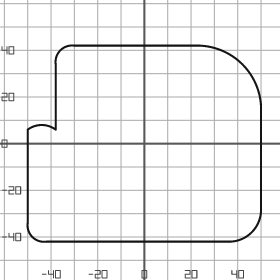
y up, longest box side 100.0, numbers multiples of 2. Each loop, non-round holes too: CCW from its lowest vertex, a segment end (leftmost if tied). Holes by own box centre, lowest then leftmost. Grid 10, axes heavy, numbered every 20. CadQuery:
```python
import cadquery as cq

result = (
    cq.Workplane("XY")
    .moveTo(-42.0, -42.0)
    .lineTo(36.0, -42.0)
    .threePointArc((46.0, -38.0), (50.0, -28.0))
    .lineTo(50.0, 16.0)
    .threePointArc((42.0, 34.0), (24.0, 42.0))
    .lineTo(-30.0, 42.0)
    .threePointArc((-36.0, 40.0), (-38.0, 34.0))
    .lineTo(-38.0, 6.0)
    .threePointArc((-44.0, 8.0), (-50.0, 6.0))
    .lineTo(-50.0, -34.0)
    .threePointArc((-48.0, -40.0), (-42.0, -42.0))
    .close()
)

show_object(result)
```